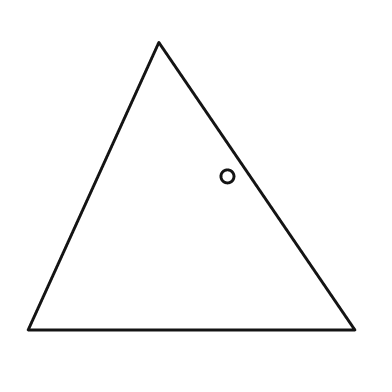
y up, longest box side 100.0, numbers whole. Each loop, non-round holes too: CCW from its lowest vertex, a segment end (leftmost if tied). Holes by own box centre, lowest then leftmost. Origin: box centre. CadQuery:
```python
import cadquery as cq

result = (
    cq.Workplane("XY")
    .moveTo(-50.0, -44.0)
    .lineTo(50.0, -44.0)
    .lineTo(-10.0, 44.0)
    .close()
    .moveTo(11.0, 3.0)
    .circle(2.0)
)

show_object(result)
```